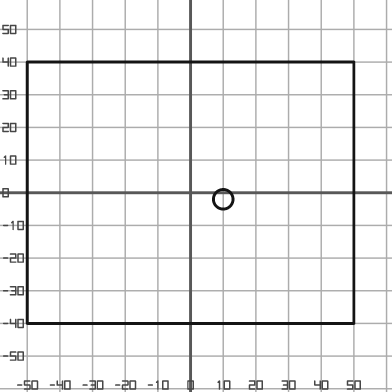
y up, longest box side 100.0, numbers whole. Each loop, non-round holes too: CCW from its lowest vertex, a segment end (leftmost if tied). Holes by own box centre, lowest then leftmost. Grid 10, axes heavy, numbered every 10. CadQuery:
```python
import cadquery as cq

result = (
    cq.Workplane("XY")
    .moveTo(-50.0, -40.0)
    .lineTo(50.0, -40.0)
    .lineTo(50.0, 40.0)
    .lineTo(-50.0, 40.0)
    .close()
    .moveTo(10.0, -2.0)
    .circle(3.0)
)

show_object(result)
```